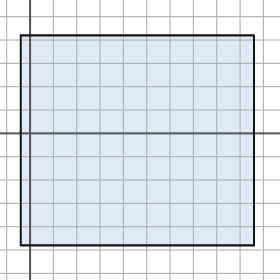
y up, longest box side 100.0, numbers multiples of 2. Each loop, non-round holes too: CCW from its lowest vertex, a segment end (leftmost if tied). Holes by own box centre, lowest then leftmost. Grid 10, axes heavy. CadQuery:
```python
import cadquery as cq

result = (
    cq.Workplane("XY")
    .moveTo(-4.0, -48.0)
    .lineTo(96.0, -48.0)
    .lineTo(96.0, 42.0)
    .lineTo(-4.0, 42.0)
    .close()
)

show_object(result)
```